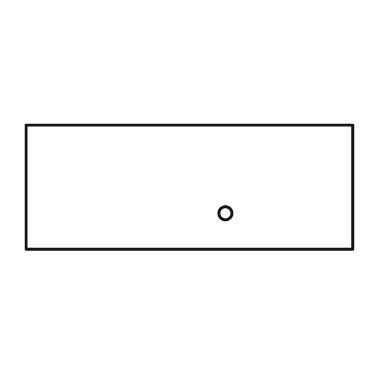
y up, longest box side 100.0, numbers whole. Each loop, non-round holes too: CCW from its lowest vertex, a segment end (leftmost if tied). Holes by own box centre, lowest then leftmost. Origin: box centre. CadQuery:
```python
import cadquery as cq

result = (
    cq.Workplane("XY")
    .moveTo(-50.0, -19.0)
    .lineTo(50.0, -19.0)
    .lineTo(50.0, 19.0)
    .lineTo(-50.0, 19.0)
    .close()
    .moveTo(11.0, -8.0)
    .circle(2.0)
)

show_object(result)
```